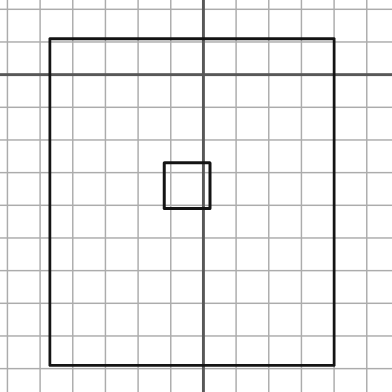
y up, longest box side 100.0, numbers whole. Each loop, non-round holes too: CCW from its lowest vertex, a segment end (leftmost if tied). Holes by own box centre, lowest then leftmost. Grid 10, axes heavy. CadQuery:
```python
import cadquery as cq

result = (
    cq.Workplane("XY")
    .moveTo(-47.0, -89.0)
    .lineTo(40.0, -89.0)
    .lineTo(40.0, 11.0)
    .lineTo(-47.0, 11.0)
    .close()
    .moveTo(-12.0, -41.0)
    .lineTo(2.0, -41.0)
    .lineTo(2.0, -27.0)
    .lineTo(-12.0, -27.0)
    .close()
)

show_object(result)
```